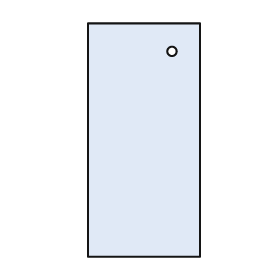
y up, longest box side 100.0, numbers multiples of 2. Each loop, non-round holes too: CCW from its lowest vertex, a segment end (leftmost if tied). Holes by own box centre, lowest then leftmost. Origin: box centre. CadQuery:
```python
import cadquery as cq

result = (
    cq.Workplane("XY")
    .moveTo(-24.0, -50.0)
    .lineTo(24.0, -50.0)
    .lineTo(24.0, 50.0)
    .lineTo(-24.0, 50.0)
    .close()
    .moveTo(12.0, 38.0)
    .circle(2.0)
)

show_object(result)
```